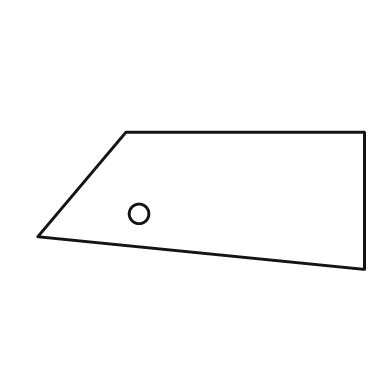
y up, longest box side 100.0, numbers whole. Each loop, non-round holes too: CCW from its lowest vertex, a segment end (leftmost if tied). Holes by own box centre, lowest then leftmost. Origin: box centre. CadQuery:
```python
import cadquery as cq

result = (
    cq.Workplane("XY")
    .moveTo(50.0, -21.0)
    .lineTo(50.0, 21.0)
    .lineTo(-23.0, 21.0)
    .lineTo(-50.0, -11.0)
    .close()
    .moveTo(-19.0, -4.0)
    .circle(3.0)
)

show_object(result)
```